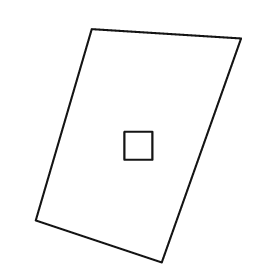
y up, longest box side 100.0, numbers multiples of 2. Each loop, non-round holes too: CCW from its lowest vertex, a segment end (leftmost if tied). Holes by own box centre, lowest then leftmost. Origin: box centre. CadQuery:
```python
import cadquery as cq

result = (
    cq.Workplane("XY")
    .moveTo(10.0, -50.0)
    .lineTo(44.0, 46.0)
    .lineTo(-20.0, 50.0)
    .lineTo(-44.0, -32.0)
    .close()
    .moveTo(-6.0, -6.0)
    .lineTo(6.0, -6.0)
    .lineTo(6.0, 6.0)
    .lineTo(-6.0, 6.0)
    .close()
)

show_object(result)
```